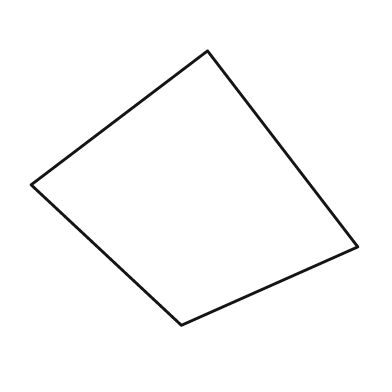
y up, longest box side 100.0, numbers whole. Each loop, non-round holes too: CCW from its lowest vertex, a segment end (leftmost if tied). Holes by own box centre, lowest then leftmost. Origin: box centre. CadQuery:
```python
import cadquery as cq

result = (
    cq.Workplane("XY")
    .moveTo(-4.0, -42.0)
    .lineTo(50.0, -18.0)
    .lineTo(4.0, 42.0)
    .lineTo(-50.0, 1.0)
    .close()
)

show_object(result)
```